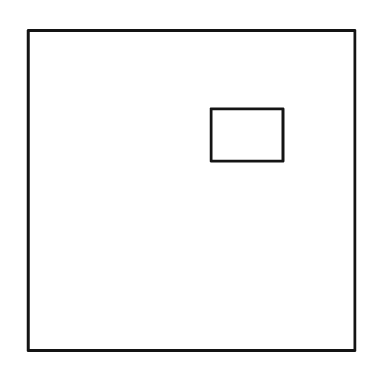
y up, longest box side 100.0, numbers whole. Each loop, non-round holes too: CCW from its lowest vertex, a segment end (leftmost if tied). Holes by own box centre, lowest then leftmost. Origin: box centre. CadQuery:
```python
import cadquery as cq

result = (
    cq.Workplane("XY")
    .moveTo(-50.0, -49.0)
    .lineTo(50.0, -49.0)
    .lineTo(50.0, 49.0)
    .lineTo(-50.0, 49.0)
    .close()
    .moveTo(6.0, 9.0)
    .lineTo(28.0, 9.0)
    .lineTo(28.0, 25.0)
    .lineTo(6.0, 25.0)
    .close()
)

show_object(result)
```